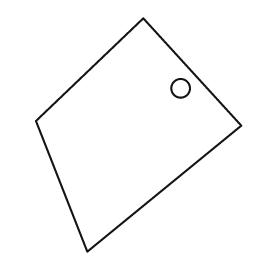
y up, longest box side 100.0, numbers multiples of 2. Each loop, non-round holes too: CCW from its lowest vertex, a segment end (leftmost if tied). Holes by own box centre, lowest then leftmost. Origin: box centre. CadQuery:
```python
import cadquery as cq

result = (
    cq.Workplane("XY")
    .moveTo(-22.0, -50.0)
    .lineTo(44.0, 4.0)
    .lineTo(2.0, 50.0)
    .lineTo(-44.0, 6.0)
    .close()
    .moveTo(18.0, 20.0)
    .circle(4.0)
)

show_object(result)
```